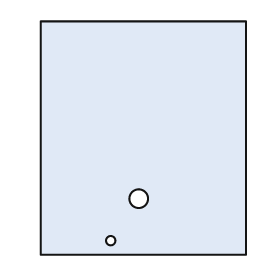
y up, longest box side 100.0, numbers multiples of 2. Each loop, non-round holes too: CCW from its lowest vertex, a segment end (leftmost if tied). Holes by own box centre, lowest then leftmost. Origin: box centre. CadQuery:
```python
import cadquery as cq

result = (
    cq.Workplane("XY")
    .moveTo(-44.0, -50.0)
    .lineTo(44.0, -50.0)
    .lineTo(44.0, 50.0)
    .lineTo(-44.0, 50.0)
    .close()
    .moveTo(-14.0, -44.0)
    .circle(2.0)
    .moveTo(-2.0, -26.0)
    .circle(4.0)
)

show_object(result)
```